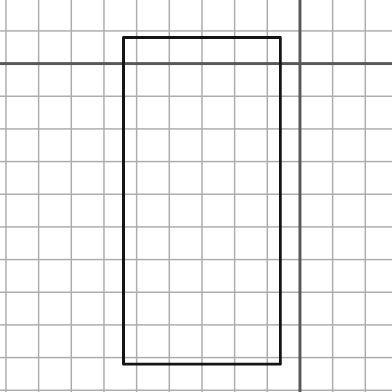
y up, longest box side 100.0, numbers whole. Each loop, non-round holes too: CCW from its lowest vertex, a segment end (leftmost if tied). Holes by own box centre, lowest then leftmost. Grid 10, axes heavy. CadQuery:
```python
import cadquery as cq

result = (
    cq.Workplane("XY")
    .moveTo(-54.0, -92.0)
    .lineTo(-6.0, -92.0)
    .lineTo(-6.0, 8.0)
    .lineTo(-54.0, 8.0)
    .close()
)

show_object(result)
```